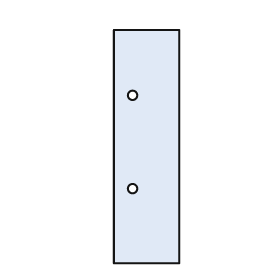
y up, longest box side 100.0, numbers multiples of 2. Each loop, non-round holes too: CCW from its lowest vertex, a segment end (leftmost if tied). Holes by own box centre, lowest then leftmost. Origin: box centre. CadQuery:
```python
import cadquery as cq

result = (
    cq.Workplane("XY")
    .moveTo(-14.0, -50.0)
    .lineTo(14.0, -50.0)
    .lineTo(14.0, 50.0)
    .lineTo(-14.0, 50.0)
    .close()
    .moveTo(-6.0, -18.0)
    .circle(2.0)
    .moveTo(-6.0, 22.0)
    .circle(2.0)
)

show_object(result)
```